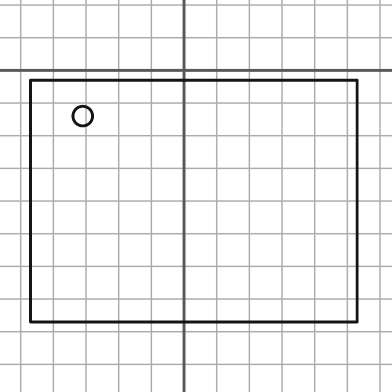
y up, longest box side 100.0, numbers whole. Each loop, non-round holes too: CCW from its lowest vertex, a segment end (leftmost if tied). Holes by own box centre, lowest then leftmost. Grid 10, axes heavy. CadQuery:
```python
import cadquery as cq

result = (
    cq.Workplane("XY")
    .moveTo(-47.0, -77.0)
    .lineTo(53.0, -77.0)
    .lineTo(53.0, -3.0)
    .lineTo(-47.0, -3.0)
    .close()
    .moveTo(-31.0, -14.0)
    .circle(3.0)
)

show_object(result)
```